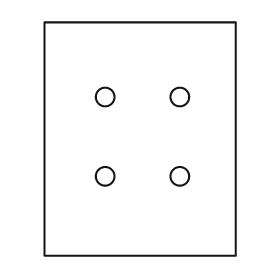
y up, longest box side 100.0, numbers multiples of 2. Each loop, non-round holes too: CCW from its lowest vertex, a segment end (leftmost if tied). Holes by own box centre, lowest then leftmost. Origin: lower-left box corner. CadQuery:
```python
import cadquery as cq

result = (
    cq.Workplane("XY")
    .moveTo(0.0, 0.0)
    .lineTo(82.0, 0.0)
    .lineTo(82.0, 100.0)
    .lineTo(0.0, 100.0)
    .close()
    .moveTo(26.0, 34.0)
    .circle(4.0)
    .moveTo(58.0, 34.0)
    .circle(4.0)
    .moveTo(26.0, 68.0)
    .circle(4.0)
    .moveTo(58.0, 68.0)
    .circle(4.0)
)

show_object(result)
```